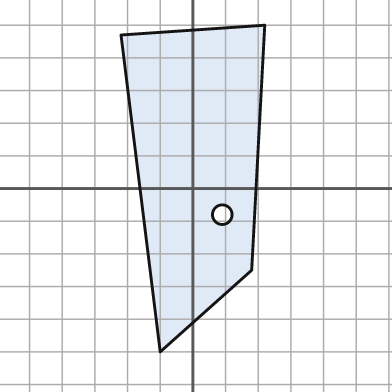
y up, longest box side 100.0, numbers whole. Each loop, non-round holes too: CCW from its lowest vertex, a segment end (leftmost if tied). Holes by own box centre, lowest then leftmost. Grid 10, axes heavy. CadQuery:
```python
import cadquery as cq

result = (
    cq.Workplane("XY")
    .moveTo(-10.0, -50.0)
    .lineTo(18.0, -25.0)
    .lineTo(22.0, 50.0)
    .lineTo(-22.0, 47.0)
    .close()
    .moveTo(9.0, -8.0)
    .circle(3.0)
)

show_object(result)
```